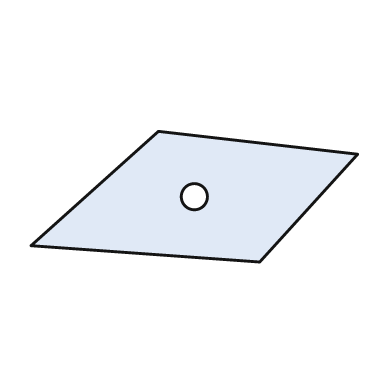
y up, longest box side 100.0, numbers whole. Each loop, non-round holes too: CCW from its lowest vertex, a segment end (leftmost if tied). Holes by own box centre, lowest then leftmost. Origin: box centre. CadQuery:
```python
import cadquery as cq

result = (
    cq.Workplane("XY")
    .moveTo(20.0, -20.0)
    .lineTo(50.0, 13.0)
    .lineTo(-11.0, 20.0)
    .lineTo(-50.0, -15.0)
    .close()
    .moveTo(0.0, 0.0)
    .circle(4.0)
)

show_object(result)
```